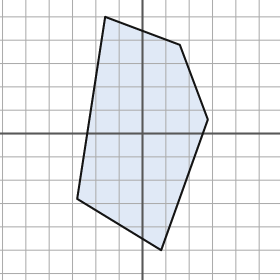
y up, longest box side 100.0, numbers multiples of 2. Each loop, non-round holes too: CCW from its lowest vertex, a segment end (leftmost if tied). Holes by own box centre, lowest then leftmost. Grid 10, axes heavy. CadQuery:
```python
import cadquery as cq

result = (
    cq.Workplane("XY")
    .moveTo(8.0, -50.0)
    .lineTo(28.0, 6.0)
    .lineTo(16.0, 38.0)
    .lineTo(-16.0, 50.0)
    .lineTo(-28.0, -28.0)
    .close()
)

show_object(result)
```